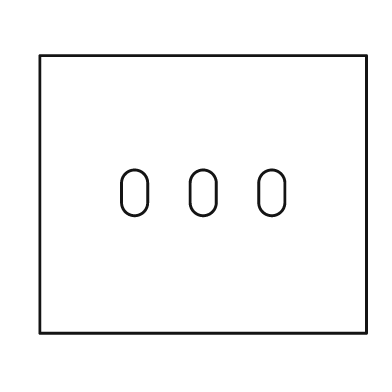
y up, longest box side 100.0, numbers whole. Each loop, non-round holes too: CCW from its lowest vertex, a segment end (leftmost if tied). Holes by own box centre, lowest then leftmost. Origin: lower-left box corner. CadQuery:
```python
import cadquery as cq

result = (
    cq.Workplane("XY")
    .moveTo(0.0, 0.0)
    .lineTo(100.0, 0.0)
    .lineTo(100.0, 85.0)
    .lineTo(0.0, 85.0)
    .close()
    .moveTo(25.0, 40.0)
    .threePointArc((29.0, 36.0), (33.0, 40.0))
    .lineTo(33.0, 46.0)
    .threePointArc((29.0, 50.0), (25.0, 46.0))
    .close()
    .moveTo(46.0, 40.0)
    .threePointArc((50.0, 36.0), (54.0, 40.0))
    .lineTo(54.0, 46.0)
    .threePointArc((50.0, 50.0), (46.0, 46.0))
    .close()
    .moveTo(67.0, 40.0)
    .threePointArc((71.0, 36.0), (75.0, 40.0))
    .lineTo(75.0, 46.0)
    .threePointArc((71.0, 50.0), (67.0, 46.0))
    .close()
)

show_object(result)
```